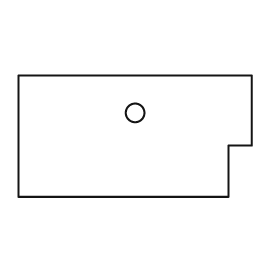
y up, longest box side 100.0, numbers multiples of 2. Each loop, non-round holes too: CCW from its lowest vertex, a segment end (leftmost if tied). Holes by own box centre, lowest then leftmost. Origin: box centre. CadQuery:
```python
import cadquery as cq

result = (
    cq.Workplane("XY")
    .moveTo(-50.0, -26.0)
    .lineTo(40.0, -26.0)
    .lineTo(40.0, -4.0)
    .lineTo(50.0, -4.0)
    .lineTo(50.0, 26.0)
    .lineTo(-50.0, 26.0)
    .close()
    .moveTo(0.0, 10.0)
    .circle(4.0)
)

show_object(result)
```